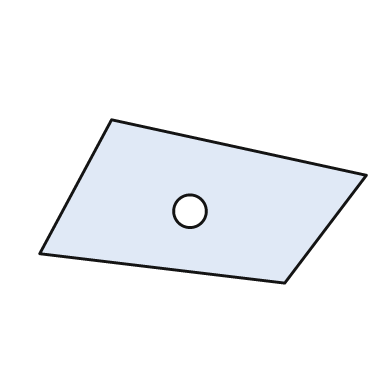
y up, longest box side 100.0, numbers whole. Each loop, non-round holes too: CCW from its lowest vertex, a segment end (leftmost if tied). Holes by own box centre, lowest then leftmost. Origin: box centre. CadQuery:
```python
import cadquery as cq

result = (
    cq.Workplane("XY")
    .moveTo(25.0, -25.0)
    .lineTo(50.0, 8.0)
    .lineTo(-28.0, 25.0)
    .lineTo(-50.0, -16.0)
    .close()
    .moveTo(-4.0, -3.0)
    .circle(5.0)
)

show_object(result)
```